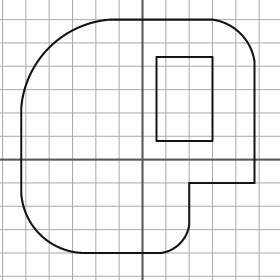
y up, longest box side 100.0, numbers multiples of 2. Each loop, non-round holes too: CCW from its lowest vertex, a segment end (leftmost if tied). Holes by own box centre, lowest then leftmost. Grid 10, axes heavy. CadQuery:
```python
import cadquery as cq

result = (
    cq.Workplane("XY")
    .moveTo(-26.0, -40.0)
    .lineTo(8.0, -40.0)
    .threePointArc((16.0, -36.0), (20.0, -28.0))
    .lineTo(20.0, -10.0)
    .lineTo(48.0, -10.0)
    .lineTo(48.0, 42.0)
    .threePointArc((42.0, 54.0), (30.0, 60.0))
    .lineTo(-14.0, 60.0)
    .threePointArc((-40.0, 48.0), (-52.0, 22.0))
    .lineTo(-52.0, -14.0)
    .threePointArc((-44.0, -32.0), (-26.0, -40.0))
    .close()
    .moveTo(6.0, 8.0)
    .lineTo(30.0, 8.0)
    .lineTo(30.0, 44.0)
    .lineTo(6.0, 44.0)
    .close()
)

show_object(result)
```